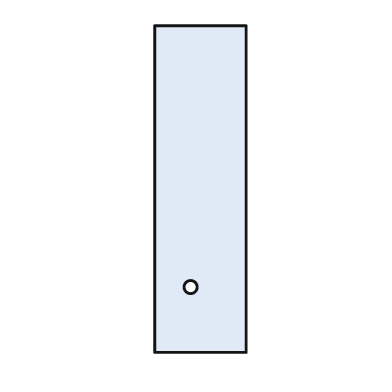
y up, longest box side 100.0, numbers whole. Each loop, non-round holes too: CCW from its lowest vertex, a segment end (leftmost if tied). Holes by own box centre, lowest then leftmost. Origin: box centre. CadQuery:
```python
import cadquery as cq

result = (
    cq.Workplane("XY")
    .moveTo(-14.0, -50.0)
    .lineTo(14.0, -50.0)
    .lineTo(14.0, 50.0)
    .lineTo(-14.0, 50.0)
    .close()
    .moveTo(-3.0, -30.0)
    .circle(2.0)
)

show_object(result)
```